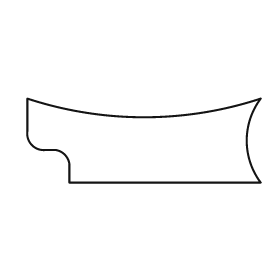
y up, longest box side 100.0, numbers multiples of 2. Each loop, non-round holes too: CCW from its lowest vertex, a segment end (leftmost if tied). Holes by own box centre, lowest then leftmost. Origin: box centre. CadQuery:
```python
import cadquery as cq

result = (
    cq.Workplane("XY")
    .moveTo(-32.0, -18.0)
    .lineTo(50.0, -18.0)
    .threePointArc((44.0, 0.0), (50.0, 18.0))
    .threePointArc((0.0, 10.0), (-50.0, 18.0))
    .lineTo(-50.0, 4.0)
    .threePointArc((-48.0, -2.0), (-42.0, -4.0))
    .lineTo(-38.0, -4.0)
    .threePointArc((-34.0, -6.0), (-32.0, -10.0))
    .close()
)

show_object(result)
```